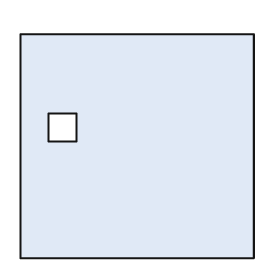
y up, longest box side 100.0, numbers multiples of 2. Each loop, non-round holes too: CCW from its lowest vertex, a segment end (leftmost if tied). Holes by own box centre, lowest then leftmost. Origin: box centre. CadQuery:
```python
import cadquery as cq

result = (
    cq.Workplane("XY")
    .moveTo(-50.0, -48.0)
    .lineTo(50.0, -48.0)
    .lineTo(50.0, 48.0)
    .lineTo(-50.0, 48.0)
    .close()
    .moveTo(-38.0, 2.0)
    .lineTo(-26.0, 2.0)
    .lineTo(-26.0, 14.0)
    .lineTo(-38.0, 14.0)
    .close()
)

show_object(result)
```